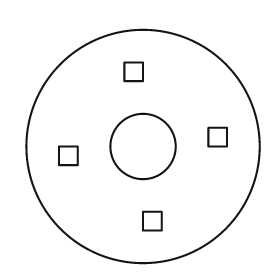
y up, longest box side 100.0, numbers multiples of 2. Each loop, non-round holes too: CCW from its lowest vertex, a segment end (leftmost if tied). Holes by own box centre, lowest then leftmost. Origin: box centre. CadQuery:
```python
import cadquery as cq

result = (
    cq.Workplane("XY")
    .moveTo(0.0, 0.0)
    .circle(50.0)
    .moveTo(0.0, -36.0)
    .lineTo(8.0, -36.0)
    .lineTo(8.0, -28.0)
    .lineTo(0.0, -28.0)
    .close()
    .moveTo(-36.0, -8.0)
    .lineTo(-28.0, -8.0)
    .lineTo(-28.0, 0.0)
    .lineTo(-36.0, 0.0)
    .close()
    .moveTo(0.0, 0.0)
    .circle(14.0)
    .moveTo(28.0, 0.0)
    .lineTo(36.0, 0.0)
    .lineTo(36.0, 8.0)
    .lineTo(28.0, 8.0)
    .close()
    .moveTo(-8.0, 28.0)
    .lineTo(0.0, 28.0)
    .lineTo(0.0, 36.0)
    .lineTo(-8.0, 36.0)
    .close()
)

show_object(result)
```